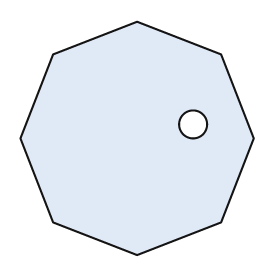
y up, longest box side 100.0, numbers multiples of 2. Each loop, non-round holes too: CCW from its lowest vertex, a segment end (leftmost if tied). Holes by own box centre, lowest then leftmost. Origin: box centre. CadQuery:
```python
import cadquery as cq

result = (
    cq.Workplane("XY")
    .moveTo(0.0, -50.0)
    .lineTo(36.0, -36.0)
    .lineTo(50.0, 0.0)
    .lineTo(36.0, 36.0)
    .lineTo(0.0, 50.0)
    .lineTo(-36.0, 36.0)
    .lineTo(-50.0, 0.0)
    .lineTo(-36.0, -36.0)
    .close()
    .moveTo(24.0, 6.0)
    .circle(6.0)
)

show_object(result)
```